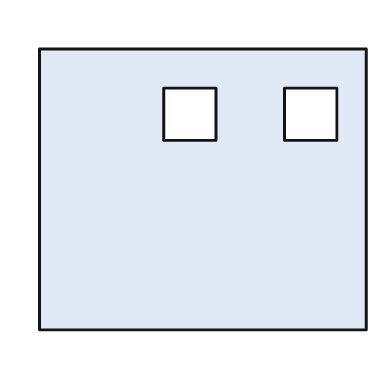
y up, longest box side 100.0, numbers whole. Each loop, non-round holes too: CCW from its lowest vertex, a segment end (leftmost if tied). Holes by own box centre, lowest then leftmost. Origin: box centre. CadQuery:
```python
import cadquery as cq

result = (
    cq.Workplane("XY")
    .moveTo(-50.0, -43.0)
    .lineTo(50.0, -43.0)
    .lineTo(50.0, 43.0)
    .lineTo(-50.0, 43.0)
    .close()
    .moveTo(-12.0, 15.0)
    .lineTo(4.0, 15.0)
    .lineTo(4.0, 31.0)
    .lineTo(-12.0, 31.0)
    .close()
    .moveTo(25.0, 15.0)
    .lineTo(41.0, 15.0)
    .lineTo(41.0, 31.0)
    .lineTo(25.0, 31.0)
    .close()
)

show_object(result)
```